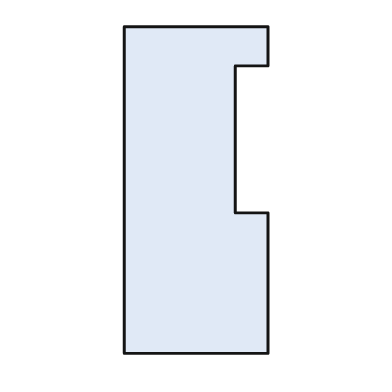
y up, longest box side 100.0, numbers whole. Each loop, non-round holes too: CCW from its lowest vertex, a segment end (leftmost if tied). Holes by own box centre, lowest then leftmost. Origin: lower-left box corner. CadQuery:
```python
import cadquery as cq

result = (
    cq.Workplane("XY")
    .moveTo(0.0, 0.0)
    .lineTo(44.0, 0.0)
    .lineTo(44.0, 43.0)
    .lineTo(34.0, 43.0)
    .lineTo(34.0, 88.0)
    .lineTo(44.0, 88.0)
    .lineTo(44.0, 100.0)
    .lineTo(0.0, 100.0)
    .close()
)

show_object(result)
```